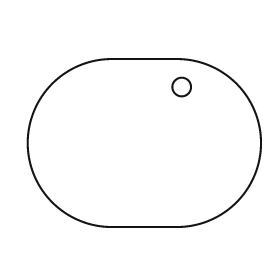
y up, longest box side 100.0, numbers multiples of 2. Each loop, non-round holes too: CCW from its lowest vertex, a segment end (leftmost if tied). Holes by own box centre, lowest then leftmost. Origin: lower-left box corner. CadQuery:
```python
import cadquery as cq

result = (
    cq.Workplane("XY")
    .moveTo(36.0, 0.0)
    .lineTo(64.0, 0.0)
    .threePointArc((100.0, 36.0), (64.0, 72.0))
    .lineTo(36.0, 72.0)
    .threePointArc((0.0, 36.0), (36.0, 0.0))
    .close()
    .moveTo(66.0, 60.0)
    .circle(4.0)
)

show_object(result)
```